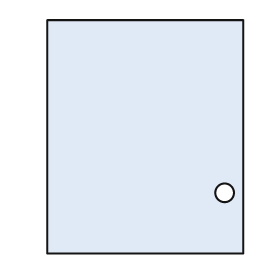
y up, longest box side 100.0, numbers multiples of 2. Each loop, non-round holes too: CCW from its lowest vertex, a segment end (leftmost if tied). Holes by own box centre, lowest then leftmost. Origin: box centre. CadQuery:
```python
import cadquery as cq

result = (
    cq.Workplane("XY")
    .moveTo(-42.0, -50.0)
    .lineTo(42.0, -50.0)
    .lineTo(42.0, 50.0)
    .lineTo(-42.0, 50.0)
    .close()
    .moveTo(34.0, -24.0)
    .circle(4.0)
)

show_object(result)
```